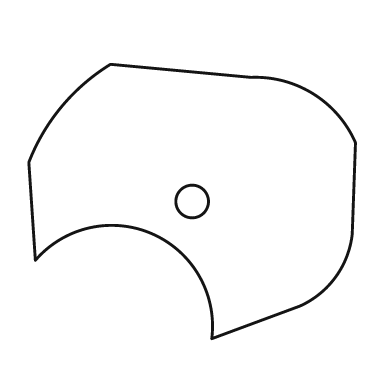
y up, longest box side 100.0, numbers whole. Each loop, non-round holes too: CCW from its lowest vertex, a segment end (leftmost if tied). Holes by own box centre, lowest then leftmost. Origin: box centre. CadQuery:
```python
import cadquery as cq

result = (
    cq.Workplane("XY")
    .moveTo(6.0, -42.0)
    .lineTo(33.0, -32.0)
    .threePointArc((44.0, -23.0), (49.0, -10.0))
    .lineTo(50.0, 18.0)
    .threePointArc((37.0, 33.0), (18.0, 38.0))
    .lineTo(-25.0, 42.0)
    .threePointArc((-40.0, 29.0), (-50.0, 12.0))
    .lineTo(-48.0, -18.0)
    .threePointArc((-12.0, -10.0), (6.0, -42.0))
    .close()
    .moveTo(0.0, 0.0)
    .circle(5.0)
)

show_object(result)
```